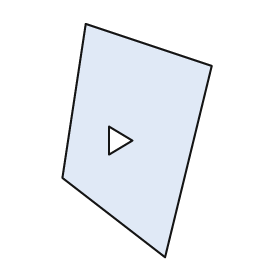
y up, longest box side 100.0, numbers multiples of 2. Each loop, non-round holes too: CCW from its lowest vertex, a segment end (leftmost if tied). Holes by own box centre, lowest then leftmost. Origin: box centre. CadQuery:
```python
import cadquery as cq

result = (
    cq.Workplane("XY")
    .moveTo(12.0, -50.0)
    .lineTo(32.0, 32.0)
    .lineTo(-22.0, 50.0)
    .lineTo(-32.0, -16.0)
    .close()
    .moveTo(-12.0, -6.0)
    .lineTo(-2.0, 0.0)
    .lineTo(-12.0, 6.0)
    .close()
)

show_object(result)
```